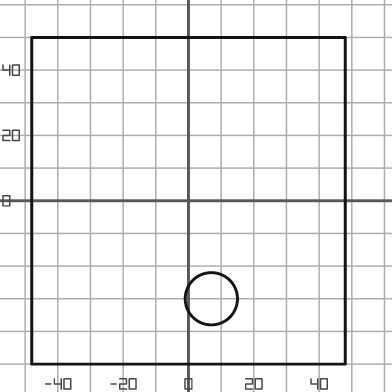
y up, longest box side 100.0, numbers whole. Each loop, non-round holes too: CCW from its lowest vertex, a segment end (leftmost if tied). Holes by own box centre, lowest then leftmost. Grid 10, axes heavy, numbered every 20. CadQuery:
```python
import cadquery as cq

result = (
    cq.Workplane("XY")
    .moveTo(-48.0, -50.0)
    .lineTo(48.0, -50.0)
    .lineTo(48.0, 50.0)
    .lineTo(-48.0, 50.0)
    .close()
    .moveTo(7.0, -30.0)
    .circle(8.0)
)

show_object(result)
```